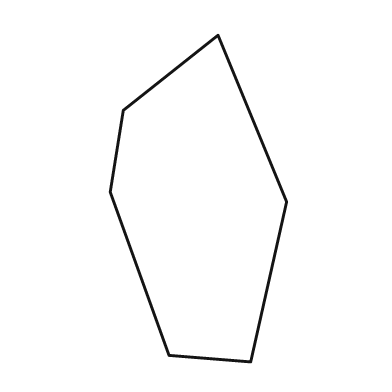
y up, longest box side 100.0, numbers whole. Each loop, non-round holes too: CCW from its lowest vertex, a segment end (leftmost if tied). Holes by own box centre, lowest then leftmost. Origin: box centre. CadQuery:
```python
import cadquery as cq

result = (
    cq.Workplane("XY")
    .moveTo(16.0, -50.0)
    .lineTo(27.0, -1.0)
    .lineTo(6.0, 50.0)
    .lineTo(-23.0, 27.0)
    .lineTo(-27.0, 2.0)
    .lineTo(-9.0, -48.0)
    .close()
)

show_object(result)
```